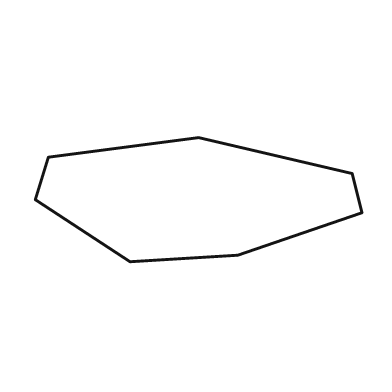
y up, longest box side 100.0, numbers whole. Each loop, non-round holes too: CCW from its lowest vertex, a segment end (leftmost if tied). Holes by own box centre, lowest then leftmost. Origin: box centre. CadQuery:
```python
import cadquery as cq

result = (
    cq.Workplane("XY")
    .moveTo(-21.0, -19.0)
    .lineTo(12.0, -17.0)
    .lineTo(50.0, -4.0)
    .lineTo(47.0, 8.0)
    .lineTo(0.0, 19.0)
    .lineTo(-46.0, 13.0)
    .lineTo(-50.0, 0.0)
    .close()
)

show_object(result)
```